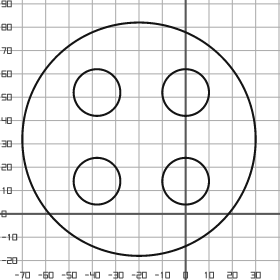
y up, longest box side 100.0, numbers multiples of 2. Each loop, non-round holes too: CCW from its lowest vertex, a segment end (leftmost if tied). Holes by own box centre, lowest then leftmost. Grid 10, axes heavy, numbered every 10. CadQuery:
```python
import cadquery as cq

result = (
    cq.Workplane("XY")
    .moveTo(-20.0, 32.0)
    .circle(50.0)
    .moveTo(-38.0, 14.0)
    .circle(10.0)
    .moveTo(0.0, 14.0)
    .circle(10.0)
    .moveTo(-38.0, 52.0)
    .circle(10.0)
    .moveTo(0.0, 52.0)
    .circle(10.0)
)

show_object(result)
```